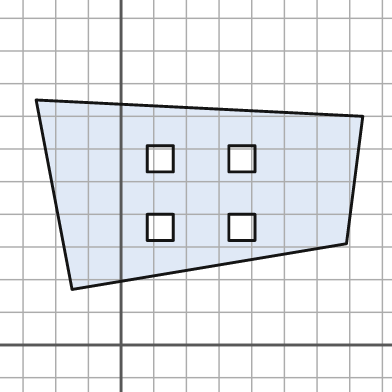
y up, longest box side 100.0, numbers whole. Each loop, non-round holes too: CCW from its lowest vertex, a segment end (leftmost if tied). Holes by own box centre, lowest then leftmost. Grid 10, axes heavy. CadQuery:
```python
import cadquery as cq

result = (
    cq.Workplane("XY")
    .moveTo(-15.0, 17.0)
    .lineTo(69.0, 31.0)
    .lineTo(74.0, 70.0)
    .lineTo(-26.0, 75.0)
    .close()
    .moveTo(8.0, 32.0)
    .lineTo(16.0, 32.0)
    .lineTo(16.0, 40.0)
    .lineTo(8.0, 40.0)
    .close()
    .moveTo(33.0, 32.0)
    .lineTo(41.0, 32.0)
    .lineTo(41.0, 40.0)
    .lineTo(33.0, 40.0)
    .close()
    .moveTo(8.0, 53.0)
    .lineTo(16.0, 53.0)
    .lineTo(16.0, 61.0)
    .lineTo(8.0, 61.0)
    .close()
    .moveTo(33.0, 53.0)
    .lineTo(41.0, 53.0)
    .lineTo(41.0, 61.0)
    .lineTo(33.0, 61.0)
    .close()
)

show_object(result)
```